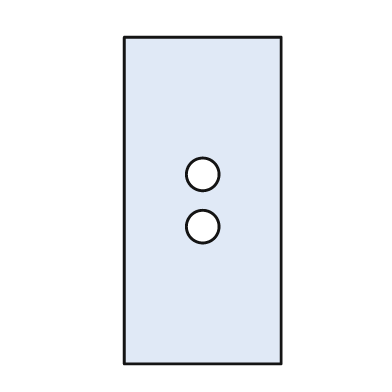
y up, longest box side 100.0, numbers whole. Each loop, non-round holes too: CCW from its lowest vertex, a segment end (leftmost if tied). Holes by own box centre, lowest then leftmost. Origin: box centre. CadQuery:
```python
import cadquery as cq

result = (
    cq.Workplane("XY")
    .moveTo(-24.0, -50.0)
    .lineTo(24.0, -50.0)
    .lineTo(24.0, 50.0)
    .lineTo(-24.0, 50.0)
    .close()
    .moveTo(0.0, -8.0)
    .circle(5.0)
    .moveTo(0.0, 8.0)
    .circle(5.0)
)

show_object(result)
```